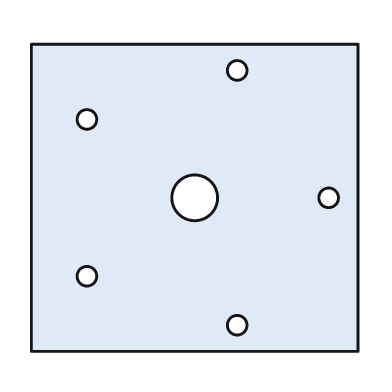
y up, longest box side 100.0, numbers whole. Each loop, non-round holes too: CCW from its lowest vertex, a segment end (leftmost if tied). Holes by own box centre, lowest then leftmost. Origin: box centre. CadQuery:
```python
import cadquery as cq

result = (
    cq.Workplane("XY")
    .moveTo(-50.0, -47.0)
    .lineTo(50.0, -47.0)
    .lineTo(50.0, 47.0)
    .lineTo(-50.0, 47.0)
    .close()
    .moveTo(13.0, -39.0)
    .circle(3.0)
    .moveTo(-33.0, -24.0)
    .circle(3.0)
    .moveTo(0.0, 0.0)
    .circle(7.0)
    .moveTo(41.0, 0.0)
    .circle(3.0)
    .moveTo(-33.0, 24.0)
    .circle(3.0)
    .moveTo(13.0, 39.0)
    .circle(3.0)
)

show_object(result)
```